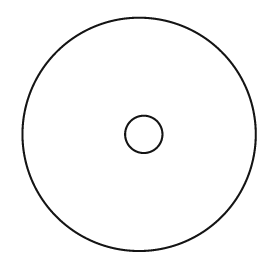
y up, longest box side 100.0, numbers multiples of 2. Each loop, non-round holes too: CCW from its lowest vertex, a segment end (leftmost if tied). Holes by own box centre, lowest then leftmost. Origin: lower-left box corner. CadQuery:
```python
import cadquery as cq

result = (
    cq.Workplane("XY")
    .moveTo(50.0, 50.0)
    .circle(50.0)
    .moveTo(52.0, 50.0)
    .circle(8.0)
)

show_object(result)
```